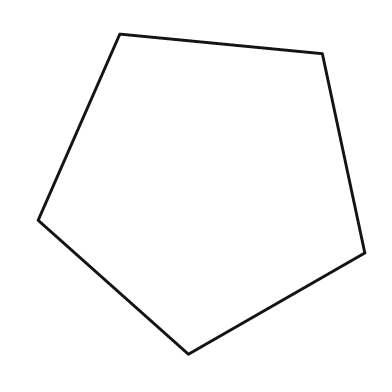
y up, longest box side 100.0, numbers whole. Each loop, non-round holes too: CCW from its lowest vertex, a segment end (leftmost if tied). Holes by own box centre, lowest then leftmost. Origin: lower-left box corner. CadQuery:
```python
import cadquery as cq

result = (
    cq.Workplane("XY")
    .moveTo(46.0, 0.0)
    .lineTo(100.0, 31.0)
    .lineTo(87.0, 92.0)
    .lineTo(25.0, 98.0)
    .lineTo(0.0, 41.0)
    .close()
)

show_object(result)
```